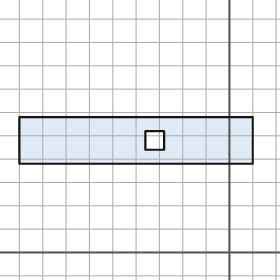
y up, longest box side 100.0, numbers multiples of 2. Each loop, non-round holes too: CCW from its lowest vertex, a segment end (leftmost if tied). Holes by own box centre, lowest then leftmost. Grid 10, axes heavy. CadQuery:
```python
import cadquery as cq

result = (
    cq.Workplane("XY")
    .moveTo(-90.0, 38.0)
    .lineTo(10.0, 38.0)
    .lineTo(10.0, 58.0)
    .lineTo(-90.0, 58.0)
    .close()
    .moveTo(-36.0, 44.0)
    .lineTo(-28.0, 44.0)
    .lineTo(-28.0, 52.0)
    .lineTo(-36.0, 52.0)
    .close()
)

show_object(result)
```